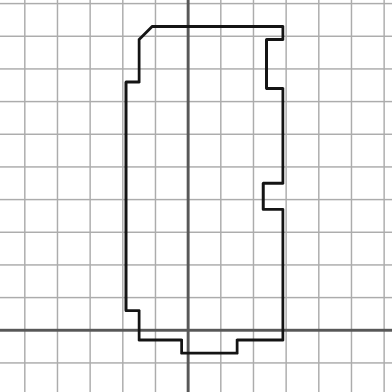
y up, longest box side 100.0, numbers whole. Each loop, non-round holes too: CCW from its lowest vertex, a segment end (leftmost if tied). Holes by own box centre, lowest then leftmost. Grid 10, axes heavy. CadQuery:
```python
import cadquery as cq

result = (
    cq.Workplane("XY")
    .moveTo(-2.0, -7.0)
    .lineTo(15.0, -7.0)
    .lineTo(15.0, -3.0)
    .lineTo(29.0, -3.0)
    .lineTo(29.0, 37.0)
    .lineTo(23.0, 37.0)
    .lineTo(23.0, 45.0)
    .lineTo(29.0, 45.0)
    .lineTo(29.0, 74.0)
    .lineTo(24.0, 74.0)
    .lineTo(24.0, 89.0)
    .lineTo(29.0, 89.0)
    .lineTo(29.0, 93.0)
    .lineTo(-11.0, 93.0)
    .lineTo(-15.0, 89.0)
    .lineTo(-15.0, 76.0)
    .lineTo(-19.0, 76.0)
    .lineTo(-19.0, 6.0)
    .lineTo(-15.0, 6.0)
    .lineTo(-15.0, -3.0)
    .lineTo(-2.0, -3.0)
    .close()
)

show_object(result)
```